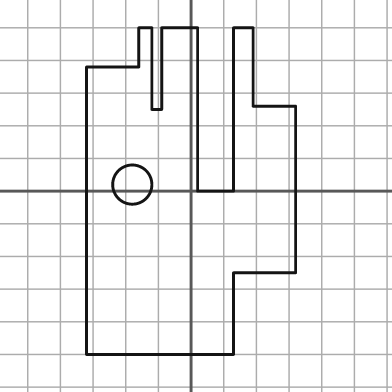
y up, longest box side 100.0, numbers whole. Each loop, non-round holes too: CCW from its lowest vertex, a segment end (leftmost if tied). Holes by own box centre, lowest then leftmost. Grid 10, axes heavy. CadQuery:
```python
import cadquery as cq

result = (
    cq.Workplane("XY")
    .moveTo(-32.0, -50.0)
    .lineTo(13.0, -50.0)
    .lineTo(13.0, -25.0)
    .lineTo(32.0, -25.0)
    .lineTo(32.0, 26.0)
    .lineTo(19.0, 26.0)
    .lineTo(19.0, 50.0)
    .lineTo(13.0, 50.0)
    .lineTo(13.0, 0.0)
    .lineTo(2.0, 0.0)
    .lineTo(2.0, 50.0)
    .lineTo(-9.0, 50.0)
    .lineTo(-9.0, 25.0)
    .lineTo(-12.0, 25.0)
    .lineTo(-12.0, 50.0)
    .lineTo(-16.0, 50.0)
    .lineTo(-16.0, 38.0)
    .lineTo(-32.0, 38.0)
    .close()
    .moveTo(-18.0, 2.0)
    .circle(6.0)
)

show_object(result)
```